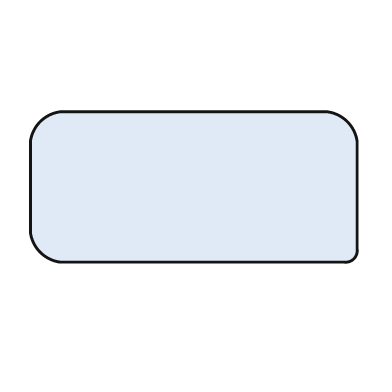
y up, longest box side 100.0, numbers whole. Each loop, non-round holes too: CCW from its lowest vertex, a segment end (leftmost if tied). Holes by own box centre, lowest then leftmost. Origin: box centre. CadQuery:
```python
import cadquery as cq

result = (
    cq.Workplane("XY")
    .moveTo(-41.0, -23.0)
    .lineTo(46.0, -23.0)
    .threePointArc((49.0, -22.0), (50.0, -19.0))
    .lineTo(50.0, 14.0)
    .threePointArc((47.0, 20.0), (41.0, 23.0))
    .lineTo(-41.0, 23.0)
    .threePointArc((-47.0, 20.0), (-50.0, 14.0))
    .lineTo(-50.0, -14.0)
    .threePointArc((-47.0, -20.0), (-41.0, -23.0))
    .close()
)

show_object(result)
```